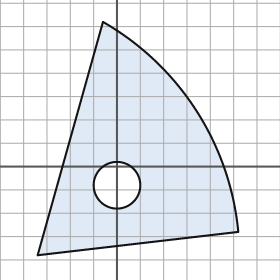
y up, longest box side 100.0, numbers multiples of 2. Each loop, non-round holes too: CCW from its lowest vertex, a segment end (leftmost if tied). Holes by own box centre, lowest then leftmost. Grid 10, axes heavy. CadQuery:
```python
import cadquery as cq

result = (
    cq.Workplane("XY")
    .moveTo(-34.0, -38.0)
    .lineTo(52.0, -28.0)
    .threePointArc((34.0, 24.0), (-6.0, 62.0))
    .close()
    .moveTo(0.0, -8.0)
    .circle(10.0)
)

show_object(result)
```